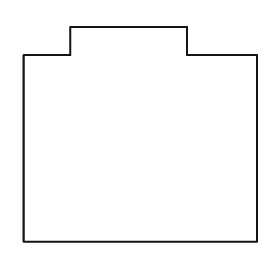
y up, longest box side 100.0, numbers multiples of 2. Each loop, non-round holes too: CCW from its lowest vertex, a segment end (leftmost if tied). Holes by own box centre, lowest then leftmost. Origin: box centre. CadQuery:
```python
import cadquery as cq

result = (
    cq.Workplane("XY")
    .moveTo(-50.0, -46.0)
    .lineTo(50.0, -46.0)
    .lineTo(50.0, 34.0)
    .lineTo(20.0, 34.0)
    .lineTo(20.0, 46.0)
    .lineTo(-30.0, 46.0)
    .lineTo(-30.0, 34.0)
    .lineTo(-50.0, 34.0)
    .close()
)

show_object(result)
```